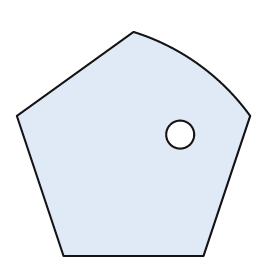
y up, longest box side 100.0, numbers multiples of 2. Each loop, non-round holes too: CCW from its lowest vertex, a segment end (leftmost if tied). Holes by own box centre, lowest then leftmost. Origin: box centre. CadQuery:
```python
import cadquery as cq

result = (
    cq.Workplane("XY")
    .moveTo(-30.0, -48.0)
    .lineTo(30.0, -48.0)
    .lineTo(50.0, 12.0)
    .threePointArc((28.0, 34.0), (0.0, 48.0))
    .lineTo(-50.0, 12.0)
    .close()
    .moveTo(20.0, 4.0)
    .circle(6.0)
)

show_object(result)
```